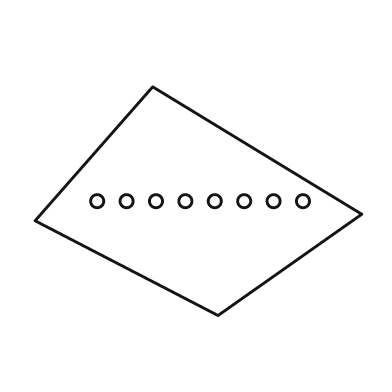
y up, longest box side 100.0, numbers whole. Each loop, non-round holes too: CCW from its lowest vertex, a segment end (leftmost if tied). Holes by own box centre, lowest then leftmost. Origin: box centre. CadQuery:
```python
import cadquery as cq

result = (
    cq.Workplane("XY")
    .moveTo(6.0, -35.0)
    .lineTo(50.0, -4.0)
    .lineTo(-14.0, 35.0)
    .lineTo(-50.0, -6.0)
    .close()
    .moveTo(-31.0, 0.0)
    .circle(2.0)
    .moveTo(-22.0, 0.0)
    .circle(2.0)
    .moveTo(-13.0, 0.0)
    .circle(2.0)
    .moveTo(-4.0, 0.0)
    .circle(2.0)
    .moveTo(5.0, 0.0)
    .circle(2.0)
    .moveTo(14.0, 0.0)
    .circle(2.0)
    .moveTo(23.0, 0.0)
    .circle(2.0)
    .moveTo(32.0, 0.0)
    .circle(2.0)
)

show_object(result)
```